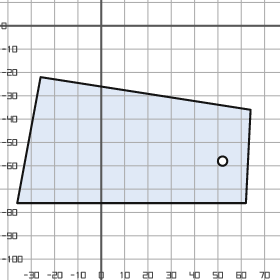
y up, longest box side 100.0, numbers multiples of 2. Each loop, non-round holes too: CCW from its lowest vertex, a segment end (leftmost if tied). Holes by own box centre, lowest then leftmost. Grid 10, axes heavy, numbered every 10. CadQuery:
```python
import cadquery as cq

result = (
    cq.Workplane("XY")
    .moveTo(-36.0, -76.0)
    .lineTo(62.0, -76.0)
    .lineTo(64.0, -36.0)
    .lineTo(-26.0, -22.0)
    .close()
    .moveTo(52.0, -58.0)
    .circle(2.0)
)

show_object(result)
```